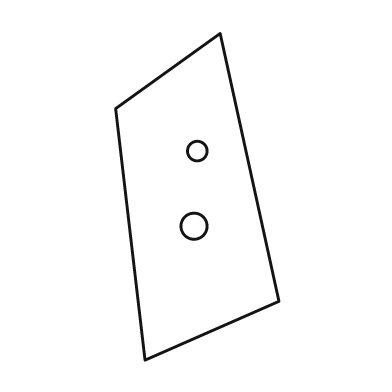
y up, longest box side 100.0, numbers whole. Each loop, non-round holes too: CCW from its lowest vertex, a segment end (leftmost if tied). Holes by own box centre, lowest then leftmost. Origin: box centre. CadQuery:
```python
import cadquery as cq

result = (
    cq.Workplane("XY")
    .moveTo(-16.0, -50.0)
    .lineTo(25.0, -32.0)
    .lineTo(7.0, 50.0)
    .lineTo(-25.0, 27.0)
    .close()
    .moveTo(-1.0, -9.0)
    .circle(4.0)
    .moveTo(0.0, 14.0)
    .circle(3.0)
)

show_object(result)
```